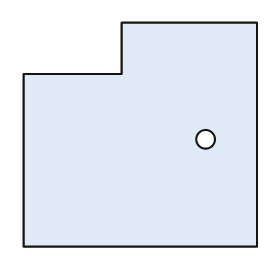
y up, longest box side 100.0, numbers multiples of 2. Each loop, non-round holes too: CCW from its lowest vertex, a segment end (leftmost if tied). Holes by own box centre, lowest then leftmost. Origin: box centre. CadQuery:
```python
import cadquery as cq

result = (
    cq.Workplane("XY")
    .moveTo(-50.0, -48.0)
    .lineTo(50.0, -48.0)
    .lineTo(50.0, 48.0)
    .lineTo(-8.0, 48.0)
    .lineTo(-8.0, 26.0)
    .lineTo(-50.0, 26.0)
    .close()
    .moveTo(28.0, -2.0)
    .circle(4.0)
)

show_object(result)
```